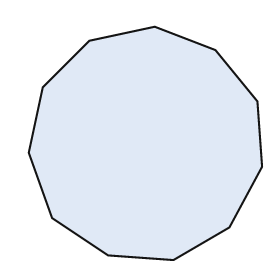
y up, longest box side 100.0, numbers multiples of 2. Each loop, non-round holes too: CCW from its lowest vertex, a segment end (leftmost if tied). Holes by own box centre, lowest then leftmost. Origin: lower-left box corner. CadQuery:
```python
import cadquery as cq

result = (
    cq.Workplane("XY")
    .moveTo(62.0, 0.0)
    .lineTo(86.0, 14.0)
    .lineTo(100.0, 40.0)
    .lineTo(98.0, 68.0)
    .lineTo(80.0, 90.0)
    .lineTo(54.0, 100.0)
    .lineTo(26.0, 94.0)
    .lineTo(6.0, 74.0)
    .lineTo(0.0, 46.0)
    .lineTo(10.0, 18.0)
    .lineTo(34.0, 2.0)
    .close()
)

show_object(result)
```